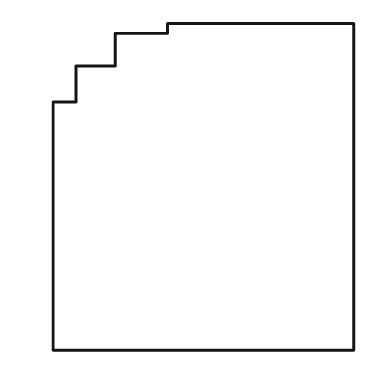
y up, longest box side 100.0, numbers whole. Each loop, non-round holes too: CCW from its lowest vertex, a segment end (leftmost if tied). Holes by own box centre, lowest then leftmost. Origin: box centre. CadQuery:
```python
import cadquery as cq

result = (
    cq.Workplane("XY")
    .moveTo(-46.0, -50.0)
    .lineTo(46.0, -50.0)
    .lineTo(46.0, 50.0)
    .lineTo(-11.0, 50.0)
    .lineTo(-11.0, 47.0)
    .lineTo(-27.0, 47.0)
    .lineTo(-27.0, 37.0)
    .lineTo(-39.0, 37.0)
    .lineTo(-39.0, 26.0)
    .lineTo(-46.0, 26.0)
    .close()
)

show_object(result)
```